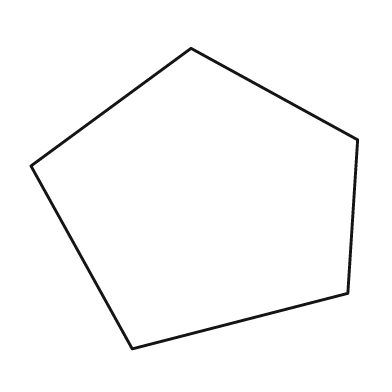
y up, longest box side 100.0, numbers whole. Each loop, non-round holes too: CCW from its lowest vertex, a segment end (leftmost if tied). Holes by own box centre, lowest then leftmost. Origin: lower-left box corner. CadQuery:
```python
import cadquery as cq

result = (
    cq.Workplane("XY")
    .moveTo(31.0, 0.0)
    .lineTo(97.0, 17.0)
    .lineTo(100.0, 64.0)
    .lineTo(49.0, 92.0)
    .lineTo(0.0, 56.0)
    .close()
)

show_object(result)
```